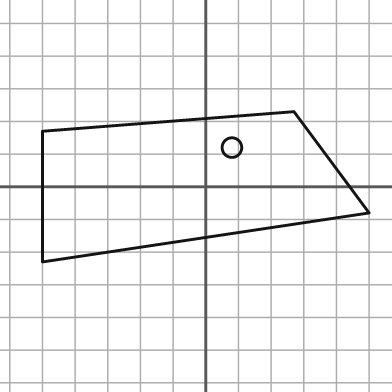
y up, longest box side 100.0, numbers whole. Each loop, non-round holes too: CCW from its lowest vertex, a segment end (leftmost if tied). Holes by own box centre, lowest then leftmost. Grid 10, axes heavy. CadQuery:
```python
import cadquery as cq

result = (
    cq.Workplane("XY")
    .moveTo(-50.0, -23.0)
    .lineTo(50.0, -8.0)
    .lineTo(27.0, 23.0)
    .lineTo(-50.0, 17.0)
    .close()
    .moveTo(8.0, 12.0)
    .circle(3.0)
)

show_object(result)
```